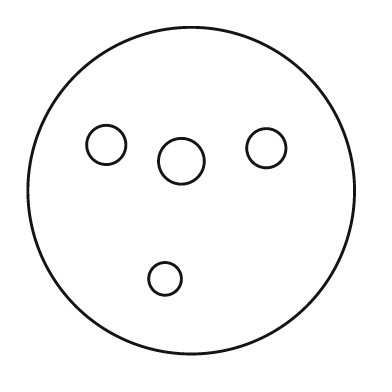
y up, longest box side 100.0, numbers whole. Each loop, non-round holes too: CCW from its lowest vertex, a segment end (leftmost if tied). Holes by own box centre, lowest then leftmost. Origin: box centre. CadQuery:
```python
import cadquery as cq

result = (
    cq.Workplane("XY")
    .moveTo(0.0, 0.0)
    .circle(50.0)
    .moveTo(-8.0, -27.0)
    .circle(5.0)
    .moveTo(-3.0, 9.0)
    .circle(7.0)
    .moveTo(23.0, 13.0)
    .circle(6.0)
    .moveTo(-26.0, 14.0)
    .circle(6.0)
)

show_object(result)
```